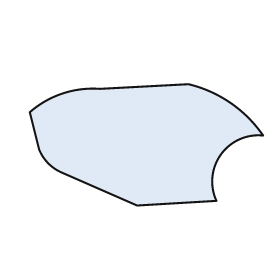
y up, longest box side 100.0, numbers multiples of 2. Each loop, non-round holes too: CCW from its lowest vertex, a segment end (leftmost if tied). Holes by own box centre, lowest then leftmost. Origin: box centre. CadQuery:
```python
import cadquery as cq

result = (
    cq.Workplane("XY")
    .moveTo(-4.0, -26.0)
    .lineTo(30.0, -24.0)
    .threePointArc((32.0, -4.0), (50.0, 4.0))
    .threePointArc((36.0, 18.0), (18.0, 26.0))
    .lineTo(-20.0, 24.0)
    .threePointArc((-36.0, 22.0), (-50.0, 14.0))
    .lineTo(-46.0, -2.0)
    .threePointArc((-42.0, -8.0), (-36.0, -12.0))
    .close()
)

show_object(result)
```